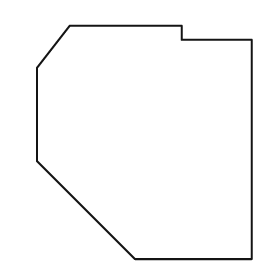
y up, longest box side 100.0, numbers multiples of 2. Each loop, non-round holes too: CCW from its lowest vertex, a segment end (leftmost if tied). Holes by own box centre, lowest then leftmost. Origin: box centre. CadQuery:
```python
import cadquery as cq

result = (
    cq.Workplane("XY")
    .moveTo(-4.0, -50.0)
    .lineTo(46.0, -50.0)
    .lineTo(46.0, 44.0)
    .lineTo(16.0, 44.0)
    .lineTo(16.0, 50.0)
    .lineTo(-32.0, 50.0)
    .lineTo(-46.0, 32.0)
    .lineTo(-46.0, -8.0)
    .close()
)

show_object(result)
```